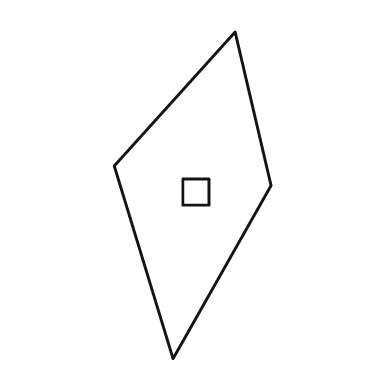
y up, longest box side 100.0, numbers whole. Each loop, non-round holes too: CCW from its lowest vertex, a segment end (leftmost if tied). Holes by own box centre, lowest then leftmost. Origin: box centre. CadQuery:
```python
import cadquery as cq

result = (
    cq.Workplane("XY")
    .moveTo(-6.0, -50.0)
    .lineTo(24.0, 3.0)
    .lineTo(13.0, 50.0)
    .lineTo(-24.0, 9.0)
    .close()
    .moveTo(-3.0, -3.0)
    .lineTo(5.0, -3.0)
    .lineTo(5.0, 5.0)
    .lineTo(-3.0, 5.0)
    .close()
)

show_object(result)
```